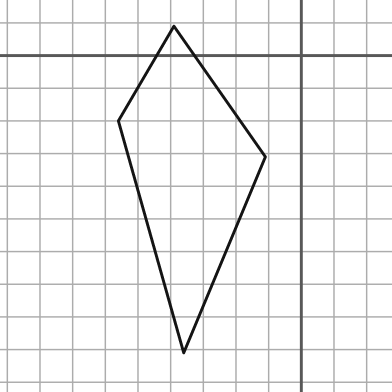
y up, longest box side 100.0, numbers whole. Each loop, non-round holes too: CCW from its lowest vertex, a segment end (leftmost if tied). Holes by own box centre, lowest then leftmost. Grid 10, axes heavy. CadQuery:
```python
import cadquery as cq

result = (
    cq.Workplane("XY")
    .moveTo(-36.0, -91.0)
    .lineTo(-11.0, -31.0)
    .lineTo(-39.0, 9.0)
    .lineTo(-56.0, -20.0)
    .close()
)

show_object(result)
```